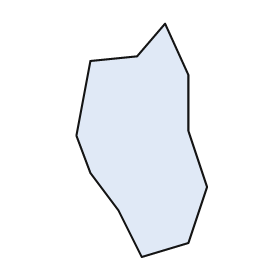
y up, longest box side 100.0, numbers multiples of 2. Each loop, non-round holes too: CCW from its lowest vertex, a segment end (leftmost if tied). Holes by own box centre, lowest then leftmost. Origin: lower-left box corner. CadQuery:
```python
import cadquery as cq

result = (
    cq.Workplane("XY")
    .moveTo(28.0, 0.0)
    .lineTo(48.0, 6.0)
    .lineTo(56.0, 30.0)
    .lineTo(48.0, 54.0)
    .lineTo(48.0, 78.0)
    .lineTo(38.0, 100.0)
    .lineTo(26.0, 86.0)
    .lineTo(6.0, 84.0)
    .lineTo(0.0, 52.0)
    .lineTo(6.0, 36.0)
    .lineTo(18.0, 20.0)
    .close()
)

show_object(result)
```